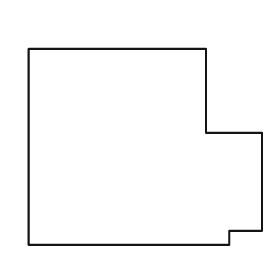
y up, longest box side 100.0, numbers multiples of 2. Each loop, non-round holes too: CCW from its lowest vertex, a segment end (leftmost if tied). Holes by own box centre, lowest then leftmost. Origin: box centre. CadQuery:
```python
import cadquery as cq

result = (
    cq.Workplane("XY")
    .moveTo(-50.0, -42.0)
    .lineTo(36.0, -42.0)
    .lineTo(36.0, -36.0)
    .lineTo(50.0, -36.0)
    .lineTo(50.0, 6.0)
    .lineTo(26.0, 6.0)
    .lineTo(26.0, 42.0)
    .lineTo(-50.0, 42.0)
    .close()
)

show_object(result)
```